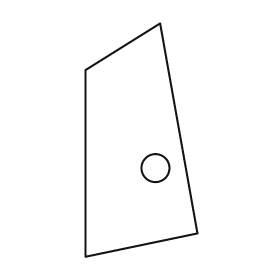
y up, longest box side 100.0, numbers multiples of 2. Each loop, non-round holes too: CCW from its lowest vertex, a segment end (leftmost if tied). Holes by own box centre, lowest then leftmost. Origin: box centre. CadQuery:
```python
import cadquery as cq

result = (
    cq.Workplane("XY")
    .moveTo(-24.0, -50.0)
    .lineTo(24.0, -40.0)
    .lineTo(8.0, 50.0)
    .lineTo(-24.0, 30.0)
    .close()
    .moveTo(6.0, -12.0)
    .circle(6.0)
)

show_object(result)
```